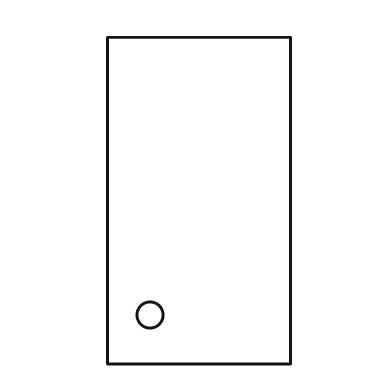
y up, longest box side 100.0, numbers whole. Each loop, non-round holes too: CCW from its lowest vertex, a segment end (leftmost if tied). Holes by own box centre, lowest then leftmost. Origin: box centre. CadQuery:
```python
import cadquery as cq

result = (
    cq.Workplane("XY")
    .moveTo(-28.0, -50.0)
    .lineTo(28.0, -50.0)
    .lineTo(28.0, 50.0)
    .lineTo(-28.0, 50.0)
    .close()
    .moveTo(-15.0, -35.0)
    .circle(4.0)
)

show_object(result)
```